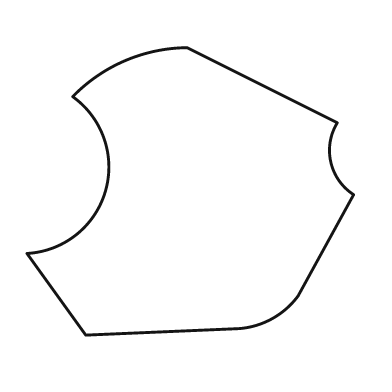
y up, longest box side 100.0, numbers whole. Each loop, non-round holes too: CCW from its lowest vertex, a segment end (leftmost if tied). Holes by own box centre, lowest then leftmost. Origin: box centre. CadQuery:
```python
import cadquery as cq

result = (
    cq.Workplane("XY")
    .moveTo(-32.0, -44.0)
    .lineTo(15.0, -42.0)
    .threePointArc((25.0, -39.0), (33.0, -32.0))
    .lineTo(50.0, -1.0)
    .threePointArc((43.0, 9.0), (45.0, 21.0))
    .lineTo(-1.0, 44.0)
    .threePointArc((-20.0, 40.0), (-36.0, 29.0))
    .threePointArc((-26.0, 0.0), (-50.0, -19.0))
    .close()
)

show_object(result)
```